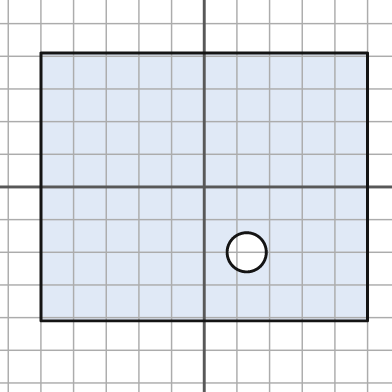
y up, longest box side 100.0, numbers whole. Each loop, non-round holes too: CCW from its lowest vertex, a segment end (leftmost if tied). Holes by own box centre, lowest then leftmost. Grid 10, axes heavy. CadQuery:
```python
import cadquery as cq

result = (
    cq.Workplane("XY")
    .moveTo(-50.0, -41.0)
    .lineTo(50.0, -41.0)
    .lineTo(50.0, 41.0)
    .lineTo(-50.0, 41.0)
    .close()
    .moveTo(13.0, -20.0)
    .circle(6.0)
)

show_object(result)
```